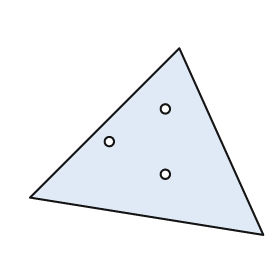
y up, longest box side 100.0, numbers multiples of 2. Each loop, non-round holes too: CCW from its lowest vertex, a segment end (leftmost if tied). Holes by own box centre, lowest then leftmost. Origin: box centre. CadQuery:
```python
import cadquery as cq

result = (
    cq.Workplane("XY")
    .moveTo(50.0, -40.0)
    .lineTo(14.0, 40.0)
    .lineTo(-50.0, -24.0)
    .close()
    .moveTo(8.0, -14.0)
    .circle(2.0)
    .moveTo(-16.0, 0.0)
    .circle(2.0)
    .moveTo(8.0, 14.0)
    .circle(2.0)
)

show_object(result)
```